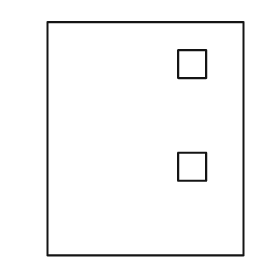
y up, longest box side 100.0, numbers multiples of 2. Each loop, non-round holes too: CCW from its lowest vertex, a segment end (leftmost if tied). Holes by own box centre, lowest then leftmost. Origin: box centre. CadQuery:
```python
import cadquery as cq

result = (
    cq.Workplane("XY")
    .moveTo(-42.0, -50.0)
    .lineTo(42.0, -50.0)
    .lineTo(42.0, 50.0)
    .lineTo(-42.0, 50.0)
    .close()
    .moveTo(14.0, -18.0)
    .lineTo(26.0, -18.0)
    .lineTo(26.0, -6.0)
    .lineTo(14.0, -6.0)
    .close()
    .moveTo(14.0, 26.0)
    .lineTo(26.0, 26.0)
    .lineTo(26.0, 38.0)
    .lineTo(14.0, 38.0)
    .close()
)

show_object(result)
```